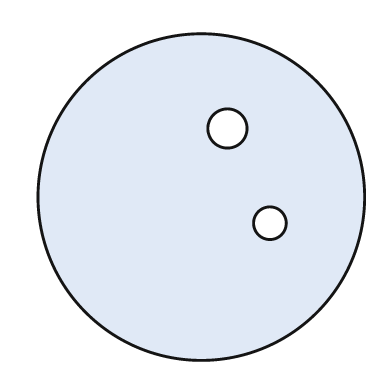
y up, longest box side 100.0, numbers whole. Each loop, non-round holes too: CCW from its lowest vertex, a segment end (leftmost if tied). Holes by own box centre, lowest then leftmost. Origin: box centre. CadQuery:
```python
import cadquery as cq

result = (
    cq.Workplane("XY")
    .moveTo(0.0, 0.0)
    .circle(50.0)
    .moveTo(21.0, -8.0)
    .circle(5.0)
    .moveTo(8.0, 21.0)
    .circle(6.0)
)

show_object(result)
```